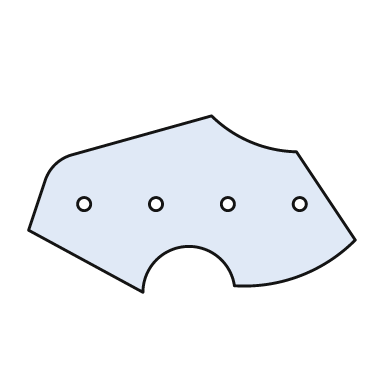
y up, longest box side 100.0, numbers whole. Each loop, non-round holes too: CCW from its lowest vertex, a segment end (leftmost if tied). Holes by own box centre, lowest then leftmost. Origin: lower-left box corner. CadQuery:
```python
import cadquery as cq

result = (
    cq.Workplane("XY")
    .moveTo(35.0, 0.0)
    .threePointArc((48.0, 14.0), (63.0, 2.0))
    .threePointArc((83.0, 5.0), (100.0, 16.0))
    .lineTo(82.0, 43.0)
    .threePointArc((68.0, 46.0), (56.0, 54.0))
    .lineTo(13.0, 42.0)
    .threePointArc((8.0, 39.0), (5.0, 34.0))
    .lineTo(0.0, 19.0)
    .close()
    .moveTo(17.0, 27.0)
    .circle(2.0)
    .moveTo(39.0, 27.0)
    .circle(2.0)
    .moveTo(61.0, 27.0)
    .circle(2.0)
    .moveTo(83.0, 27.0)
    .circle(2.0)
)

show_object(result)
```